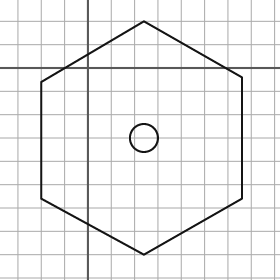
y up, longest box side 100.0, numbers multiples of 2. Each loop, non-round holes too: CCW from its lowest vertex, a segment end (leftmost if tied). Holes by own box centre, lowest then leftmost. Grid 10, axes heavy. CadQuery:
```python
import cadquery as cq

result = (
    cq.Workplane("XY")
    .moveTo(24.0, -80.0)
    .lineTo(66.0, -56.0)
    .lineTo(66.0, -4.0)
    .lineTo(24.0, 20.0)
    .lineTo(-20.0, -6.0)
    .lineTo(-20.0, -56.0)
    .close()
    .moveTo(24.0, -30.0)
    .circle(6.0)
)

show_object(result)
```